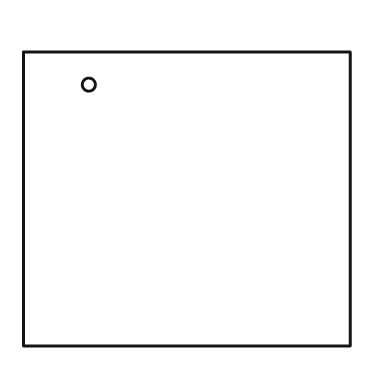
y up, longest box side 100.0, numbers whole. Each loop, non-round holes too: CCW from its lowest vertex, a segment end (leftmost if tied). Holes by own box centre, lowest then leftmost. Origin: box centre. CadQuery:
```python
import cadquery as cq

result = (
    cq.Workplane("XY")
    .moveTo(-50.0, -45.0)
    .lineTo(50.0, -45.0)
    .lineTo(50.0, 45.0)
    .lineTo(-50.0, 45.0)
    .close()
    .moveTo(-30.0, 35.0)
    .circle(2.0)
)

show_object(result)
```